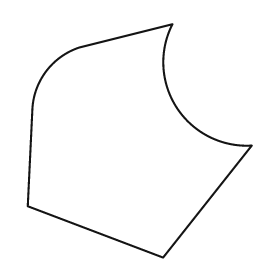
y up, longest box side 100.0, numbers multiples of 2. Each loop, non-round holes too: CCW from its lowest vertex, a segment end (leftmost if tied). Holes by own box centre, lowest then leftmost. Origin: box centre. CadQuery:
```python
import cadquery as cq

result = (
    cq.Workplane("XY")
    .moveTo(10.0, -50.0)
    .lineTo(48.0, -2.0)
    .threePointArc((16.0, 14.0), (14.0, 50.0))
    .lineTo(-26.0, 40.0)
    .threePointArc((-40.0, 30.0), (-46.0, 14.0))
    .lineTo(-48.0, -28.0)
    .close()
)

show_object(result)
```